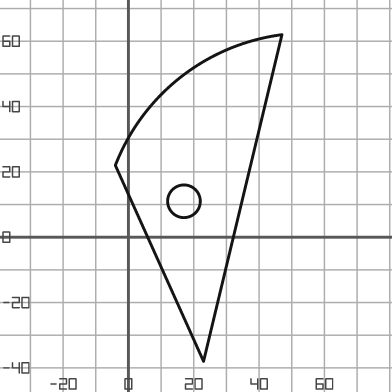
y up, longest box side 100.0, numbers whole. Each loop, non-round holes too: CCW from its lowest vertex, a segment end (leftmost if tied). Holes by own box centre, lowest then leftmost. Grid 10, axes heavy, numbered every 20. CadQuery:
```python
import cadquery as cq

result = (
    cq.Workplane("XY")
    .moveTo(23.0, -38.0)
    .lineTo(47.0, 62.0)
    .threePointArc((16.0, 49.0), (-4.0, 22.0))
    .close()
    .moveTo(17.0, 11.0)
    .circle(5.0)
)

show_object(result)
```